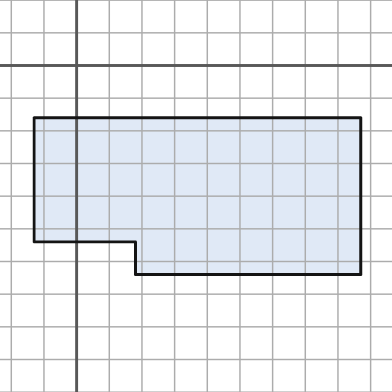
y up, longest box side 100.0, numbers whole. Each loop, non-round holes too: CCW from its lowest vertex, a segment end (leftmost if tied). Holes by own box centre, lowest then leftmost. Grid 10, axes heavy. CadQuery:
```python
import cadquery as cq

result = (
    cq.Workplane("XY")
    .moveTo(18.0, -64.0)
    .lineTo(87.0, -64.0)
    .lineTo(87.0, -16.0)
    .lineTo(-13.0, -16.0)
    .lineTo(-13.0, -54.0)
    .lineTo(18.0, -54.0)
    .close()
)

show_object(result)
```